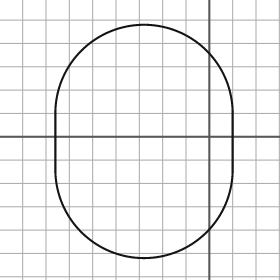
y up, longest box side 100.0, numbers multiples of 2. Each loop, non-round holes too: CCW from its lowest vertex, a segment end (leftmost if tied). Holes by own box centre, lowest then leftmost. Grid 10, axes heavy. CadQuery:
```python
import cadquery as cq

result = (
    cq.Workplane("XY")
    .moveTo(-66.0, -14.0)
    .threePointArc((-28.0, -52.0), (10.0, -14.0))
    .lineTo(10.0, 10.0)
    .threePointArc((-28.0, 48.0), (-66.0, 10.0))
    .close()
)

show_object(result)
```